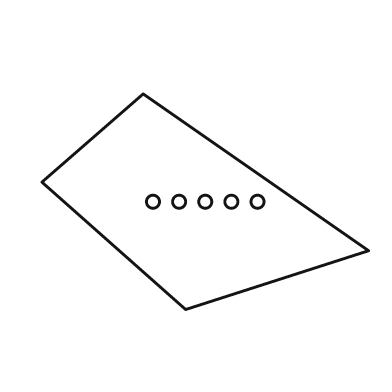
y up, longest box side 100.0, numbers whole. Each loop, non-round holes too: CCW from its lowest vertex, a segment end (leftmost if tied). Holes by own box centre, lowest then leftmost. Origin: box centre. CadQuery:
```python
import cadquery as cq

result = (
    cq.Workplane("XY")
    .moveTo(-6.0, -33.0)
    .lineTo(50.0, -15.0)
    .lineTo(-19.0, 33.0)
    .lineTo(-50.0, 6.0)
    .close()
    .moveTo(-16.0, 0.0)
    .circle(2.0)
    .moveTo(-8.0, 0.0)
    .circle(2.0)
    .moveTo(0.0, 0.0)
    .circle(2.0)
    .moveTo(8.0, 0.0)
    .circle(2.0)
    .moveTo(16.0, 0.0)
    .circle(2.0)
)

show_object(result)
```